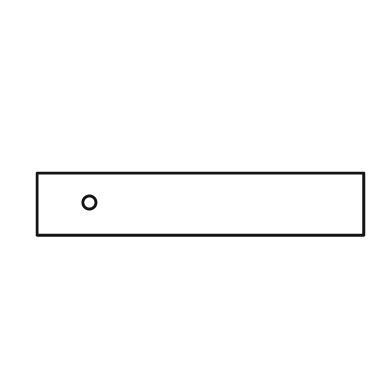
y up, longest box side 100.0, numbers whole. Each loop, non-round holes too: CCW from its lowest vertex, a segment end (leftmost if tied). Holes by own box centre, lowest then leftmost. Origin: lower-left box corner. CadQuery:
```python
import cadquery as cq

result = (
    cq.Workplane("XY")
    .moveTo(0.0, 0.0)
    .lineTo(100.0, 0.0)
    .lineTo(100.0, 19.0)
    .lineTo(0.0, 19.0)
    .close()
    .moveTo(16.0, 10.0)
    .circle(2.0)
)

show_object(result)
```